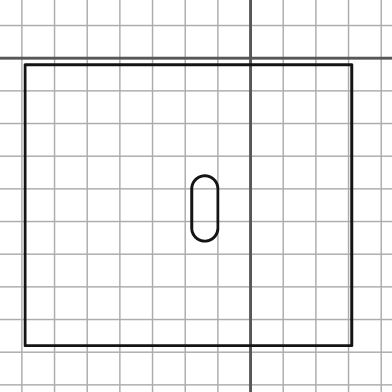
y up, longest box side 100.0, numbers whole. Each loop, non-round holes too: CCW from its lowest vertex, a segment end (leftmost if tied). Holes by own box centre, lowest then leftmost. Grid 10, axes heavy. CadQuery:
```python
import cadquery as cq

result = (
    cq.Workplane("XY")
    .moveTo(-69.0, -88.0)
    .lineTo(31.0, -88.0)
    .lineTo(31.0, -2.0)
    .lineTo(-69.0, -2.0)
    .close()
    .moveTo(-18.0, -52.0)
    .threePointArc((-14.0, -56.0), (-10.0, -52.0))
    .lineTo(-10.0, -40.0)
    .threePointArc((-14.0, -36.0), (-18.0, -40.0))
    .close()
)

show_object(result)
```